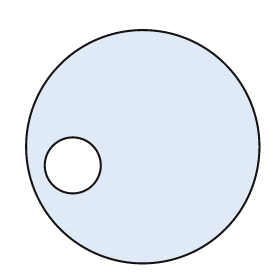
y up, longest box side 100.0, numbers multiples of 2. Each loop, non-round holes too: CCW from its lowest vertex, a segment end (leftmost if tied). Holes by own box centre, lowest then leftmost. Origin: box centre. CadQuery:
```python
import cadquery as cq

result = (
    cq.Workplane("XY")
    .moveTo(0.0, 0.0)
    .circle(50.0)
    .moveTo(-30.0, -8.0)
    .circle(12.0)
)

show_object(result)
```